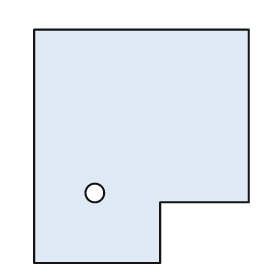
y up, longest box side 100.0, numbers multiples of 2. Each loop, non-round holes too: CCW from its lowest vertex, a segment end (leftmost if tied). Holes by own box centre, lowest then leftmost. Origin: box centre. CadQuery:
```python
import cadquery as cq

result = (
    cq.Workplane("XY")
    .moveTo(-46.0, -50.0)
    .lineTo(8.0, -50.0)
    .lineTo(8.0, -24.0)
    .lineTo(46.0, -24.0)
    .lineTo(46.0, 50.0)
    .lineTo(-46.0, 50.0)
    .close()
    .moveTo(-20.0, -20.0)
    .circle(4.0)
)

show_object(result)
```